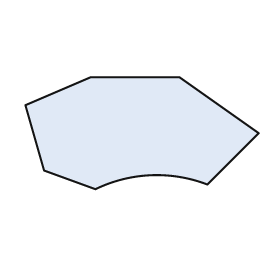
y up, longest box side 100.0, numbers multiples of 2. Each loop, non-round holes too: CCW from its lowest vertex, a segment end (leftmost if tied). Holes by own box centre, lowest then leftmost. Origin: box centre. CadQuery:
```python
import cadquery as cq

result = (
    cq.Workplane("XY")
    .moveTo(-20.0, -24.0)
    .threePointArc((4.0, -18.0), (28.0, -22.0))
    .lineTo(50.0, 0.0)
    .lineTo(16.0, 24.0)
    .lineTo(-22.0, 24.0)
    .lineTo(-50.0, 12.0)
    .lineTo(-42.0, -16.0)
    .close()
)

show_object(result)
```